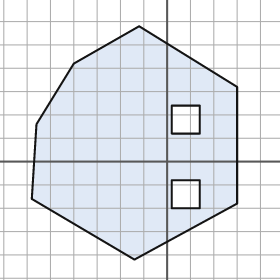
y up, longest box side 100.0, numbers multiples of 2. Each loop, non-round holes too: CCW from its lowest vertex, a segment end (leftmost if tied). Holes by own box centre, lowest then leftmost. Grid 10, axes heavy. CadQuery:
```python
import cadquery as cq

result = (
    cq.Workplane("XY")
    .moveTo(-14.0, -42.0)
    .lineTo(30.0, -18.0)
    .lineTo(30.0, 32.0)
    .lineTo(-12.0, 58.0)
    .lineTo(-40.0, 42.0)
    .lineTo(-56.0, 16.0)
    .lineTo(-58.0, -16.0)
    .close()
    .moveTo(2.0, -20.0)
    .lineTo(14.0, -20.0)
    .lineTo(14.0, -8.0)
    .lineTo(2.0, -8.0)
    .close()
    .moveTo(2.0, 12.0)
    .lineTo(14.0, 12.0)
    .lineTo(14.0, 24.0)
    .lineTo(2.0, 24.0)
    .close()
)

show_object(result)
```